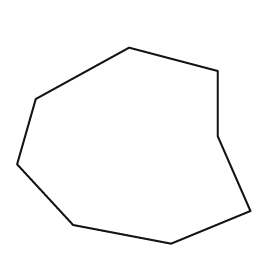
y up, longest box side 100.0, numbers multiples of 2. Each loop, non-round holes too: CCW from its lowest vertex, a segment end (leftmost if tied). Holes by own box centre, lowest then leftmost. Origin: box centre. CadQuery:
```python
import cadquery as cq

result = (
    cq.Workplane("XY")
    .moveTo(16.0, -42.0)
    .lineTo(50.0, -28.0)
    .lineTo(36.0, 4.0)
    .lineTo(36.0, 32.0)
    .lineTo(-2.0, 42.0)
    .lineTo(-42.0, 20.0)
    .lineTo(-50.0, -8.0)
    .lineTo(-26.0, -34.0)
    .close()
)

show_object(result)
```